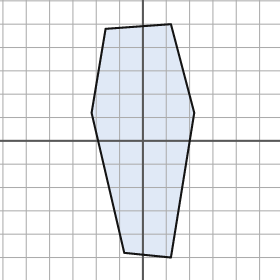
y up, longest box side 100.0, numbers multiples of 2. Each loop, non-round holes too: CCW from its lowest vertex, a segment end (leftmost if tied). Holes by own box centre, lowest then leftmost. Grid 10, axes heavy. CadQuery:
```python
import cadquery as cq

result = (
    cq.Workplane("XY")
    .moveTo(12.0, -50.0)
    .lineTo(22.0, 12.0)
    .lineTo(12.0, 50.0)
    .lineTo(-16.0, 48.0)
    .lineTo(-22.0, 12.0)
    .lineTo(-8.0, -48.0)
    .close()
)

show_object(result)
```